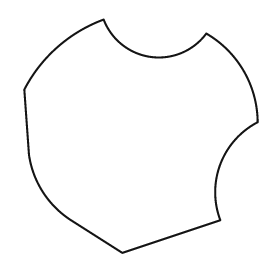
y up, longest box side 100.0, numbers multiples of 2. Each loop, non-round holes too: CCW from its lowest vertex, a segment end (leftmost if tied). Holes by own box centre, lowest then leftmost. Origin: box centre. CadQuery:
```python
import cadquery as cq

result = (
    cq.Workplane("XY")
    .moveTo(-8.0, -50.0)
    .lineTo(34.0, -36.0)
    .threePointArc((34.0, -12.0), (50.0, 6.0))
    .threePointArc((44.0, 28.0), (28.0, 44.0))
    .threePointArc((4.0, 34.0), (-16.0, 50.0))
    .threePointArc((-36.0, 38.0), (-50.0, 20.0))
    .lineTo(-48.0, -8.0)
    .threePointArc((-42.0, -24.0), (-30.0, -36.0))
    .close()
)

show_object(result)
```